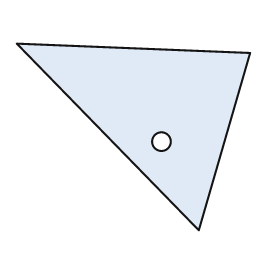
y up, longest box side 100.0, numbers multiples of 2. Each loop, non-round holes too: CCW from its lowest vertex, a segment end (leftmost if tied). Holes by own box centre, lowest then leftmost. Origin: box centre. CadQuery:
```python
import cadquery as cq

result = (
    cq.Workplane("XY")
    .moveTo(28.0, -40.0)
    .lineTo(50.0, 36.0)
    .lineTo(-50.0, 40.0)
    .close()
    .moveTo(12.0, -2.0)
    .circle(4.0)
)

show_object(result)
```